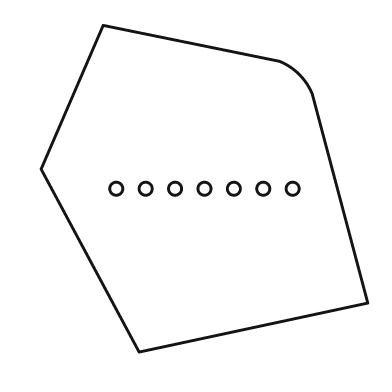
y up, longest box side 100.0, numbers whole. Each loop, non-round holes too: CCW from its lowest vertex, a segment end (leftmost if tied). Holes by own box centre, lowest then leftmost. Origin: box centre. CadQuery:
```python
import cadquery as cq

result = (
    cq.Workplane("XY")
    .moveTo(-20.0, -50.0)
    .lineTo(50.0, -35.0)
    .lineTo(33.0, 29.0)
    .threePointArc((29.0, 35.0), (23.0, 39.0))
    .lineTo(-31.0, 50.0)
    .lineTo(-50.0, 6.0)
    .close()
    .moveTo(-27.0, 0.0)
    .circle(2.0)
    .moveTo(-18.0, 0.0)
    .circle(2.0)
    .moveTo(-9.0, 0.0)
    .circle(2.0)
    .moveTo(0.0, 0.0)
    .circle(2.0)
    .moveTo(9.0, 0.0)
    .circle(2.0)
    .moveTo(18.0, 0.0)
    .circle(2.0)
    .moveTo(27.0, 0.0)
    .circle(2.0)
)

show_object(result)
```